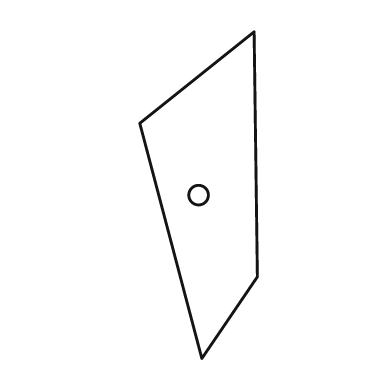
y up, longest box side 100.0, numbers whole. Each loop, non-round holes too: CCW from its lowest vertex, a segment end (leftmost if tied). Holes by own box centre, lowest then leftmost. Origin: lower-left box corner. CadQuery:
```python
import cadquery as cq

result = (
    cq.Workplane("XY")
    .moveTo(19.0, 0.0)
    .lineTo(36.0, 25.0)
    .lineTo(35.0, 100.0)
    .lineTo(0.0, 72.0)
    .close()
    .moveTo(18.0, 50.0)
    .circle(3.0)
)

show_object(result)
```